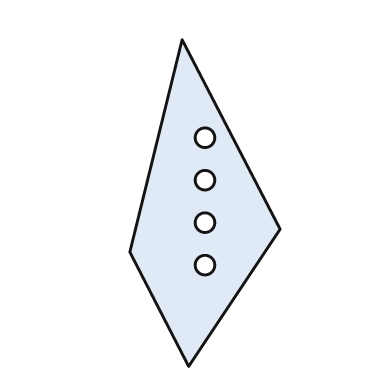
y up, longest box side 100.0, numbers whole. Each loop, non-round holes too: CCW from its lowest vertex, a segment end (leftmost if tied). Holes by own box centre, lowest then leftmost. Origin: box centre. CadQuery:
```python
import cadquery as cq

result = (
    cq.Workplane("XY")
    .moveTo(-5.0, -50.0)
    .lineTo(23.0, -8.0)
    .lineTo(-7.0, 50.0)
    .lineTo(-23.0, -15.0)
    .close()
    .moveTo(0.0, -19.0)
    .circle(3.0)
    .moveTo(0.0, -6.0)
    .circle(3.0)
    .moveTo(0.0, 7.0)
    .circle(3.0)
    .moveTo(0.0, 20.0)
    .circle(3.0)
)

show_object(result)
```